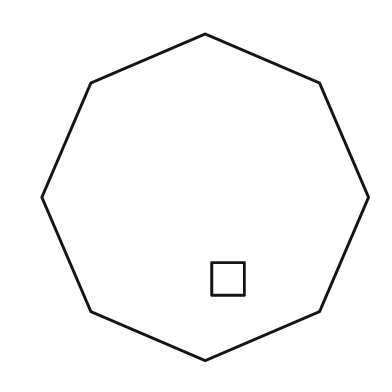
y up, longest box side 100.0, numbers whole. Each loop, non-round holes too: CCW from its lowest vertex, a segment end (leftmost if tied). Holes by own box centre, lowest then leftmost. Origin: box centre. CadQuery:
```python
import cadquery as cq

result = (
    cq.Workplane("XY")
    .moveTo(0.0, -50.0)
    .lineTo(35.0, -35.0)
    .lineTo(50.0, 0.0)
    .lineTo(35.0, 35.0)
    .lineTo(0.0, 50.0)
    .lineTo(-35.0, 35.0)
    .lineTo(-50.0, 0.0)
    .lineTo(-35.0, -35.0)
    .close()
    .moveTo(2.0, -30.0)
    .lineTo(12.0, -30.0)
    .lineTo(12.0, -20.0)
    .lineTo(2.0, -20.0)
    .close()
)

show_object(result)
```